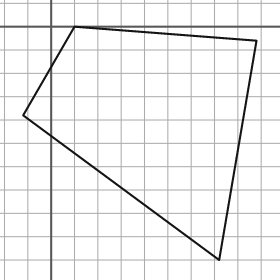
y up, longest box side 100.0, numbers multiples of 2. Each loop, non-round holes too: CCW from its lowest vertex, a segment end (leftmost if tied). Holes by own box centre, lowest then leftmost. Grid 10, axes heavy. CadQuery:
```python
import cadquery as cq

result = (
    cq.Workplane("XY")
    .moveTo(72.0, -100.0)
    .lineTo(88.0, -6.0)
    .lineTo(10.0, 0.0)
    .lineTo(-12.0, -38.0)
    .close()
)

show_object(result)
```